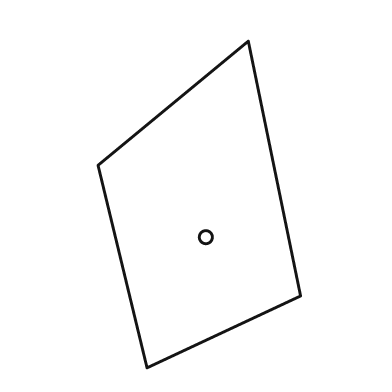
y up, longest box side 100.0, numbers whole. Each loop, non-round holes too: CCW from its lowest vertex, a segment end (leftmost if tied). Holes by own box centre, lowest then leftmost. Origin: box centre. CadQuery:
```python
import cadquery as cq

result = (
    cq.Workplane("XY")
    .moveTo(-16.0, -50.0)
    .lineTo(31.0, -28.0)
    .lineTo(15.0, 50.0)
    .lineTo(-31.0, 12.0)
    .close()
    .moveTo(2.0, -10.0)
    .circle(2.0)
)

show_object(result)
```